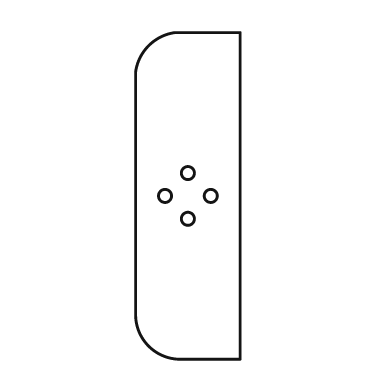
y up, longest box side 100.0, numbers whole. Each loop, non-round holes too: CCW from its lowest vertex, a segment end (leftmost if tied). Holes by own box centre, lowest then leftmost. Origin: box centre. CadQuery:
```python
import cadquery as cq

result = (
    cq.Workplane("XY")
    .moveTo(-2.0, -50.0)
    .lineTo(16.0, -50.0)
    .lineTo(16.0, 50.0)
    .lineTo(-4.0, 50.0)
    .threePointArc((-12.0, 46.0), (-16.0, 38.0))
    .lineTo(-16.0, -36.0)
    .threePointArc((-12.0, -46.0), (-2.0, -50.0))
    .close()
    .moveTo(0.0, -7.0)
    .circle(2.0)
    .moveTo(-7.0, 0.0)
    .circle(2.0)
    .moveTo(7.0, 0.0)
    .circle(2.0)
    .moveTo(0.0, 7.0)
    .circle(2.0)
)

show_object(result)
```